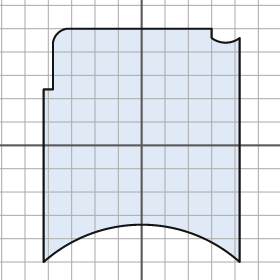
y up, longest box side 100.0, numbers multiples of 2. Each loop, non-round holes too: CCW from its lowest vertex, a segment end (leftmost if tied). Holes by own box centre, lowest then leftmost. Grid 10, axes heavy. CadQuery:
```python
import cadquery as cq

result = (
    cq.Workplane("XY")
    .moveTo(-42.0, -50.0)
    .threePointArc((0.0, -34.0), (42.0, -50.0))
    .lineTo(42.0, 46.0)
    .threePointArc((36.0, 44.0), (30.0, 46.0))
    .lineTo(30.0, 50.0)
    .lineTo(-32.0, 50.0)
    .threePointArc((-36.0, 48.0), (-38.0, 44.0))
    .lineTo(-38.0, 24.0)
    .lineTo(-42.0, 24.0)
    .close()
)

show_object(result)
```